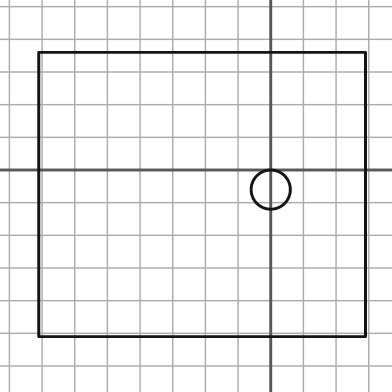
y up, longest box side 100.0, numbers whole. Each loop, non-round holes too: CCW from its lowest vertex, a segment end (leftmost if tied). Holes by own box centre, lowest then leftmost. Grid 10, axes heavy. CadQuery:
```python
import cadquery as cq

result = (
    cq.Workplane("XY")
    .moveTo(-71.0, -51.0)
    .lineTo(29.0, -51.0)
    .lineTo(29.0, 36.0)
    .lineTo(-71.0, 36.0)
    .close()
    .moveTo(0.0, -6.0)
    .circle(6.0)
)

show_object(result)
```